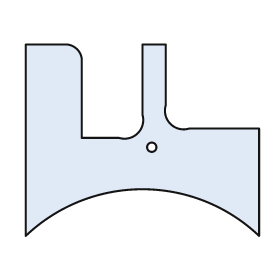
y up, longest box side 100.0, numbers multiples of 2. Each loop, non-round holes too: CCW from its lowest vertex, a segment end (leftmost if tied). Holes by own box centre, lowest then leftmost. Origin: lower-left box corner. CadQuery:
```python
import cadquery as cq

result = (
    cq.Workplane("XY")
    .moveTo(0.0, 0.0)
    .threePointArc((50.0, 20.0), (100.0, 0.0))
    .lineTo(100.0, 46.0)
    .lineTo(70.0, 46.0)
    .threePointArc((62.0, 48.0), (60.0, 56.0))
    .lineTo(60.0, 82.0)
    .lineTo(50.0, 82.0)
    .lineTo(50.0, 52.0)
    .threePointArc((48.0, 44.0), (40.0, 42.0))
    .lineTo(24.0, 42.0)
    .lineTo(24.0, 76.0)
    .threePointArc((22.0, 80.0), (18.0, 82.0))
    .lineTo(0.0, 82.0)
    .close()
    .moveTo(54.0, 38.0)
    .circle(2.0)
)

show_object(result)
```